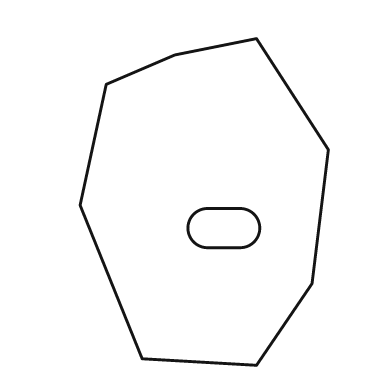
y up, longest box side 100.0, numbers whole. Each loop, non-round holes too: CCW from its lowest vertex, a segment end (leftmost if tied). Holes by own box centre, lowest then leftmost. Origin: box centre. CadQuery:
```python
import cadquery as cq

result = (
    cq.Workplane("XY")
    .moveTo(16.0, -50.0)
    .lineTo(33.0, -25.0)
    .lineTo(38.0, 16.0)
    .lineTo(16.0, 50.0)
    .lineTo(-9.0, 45.0)
    .lineTo(-30.0, 36.0)
    .lineTo(-38.0, -1.0)
    .lineTo(-19.0, -48.0)
    .close()
    .moveTo(1.0, -14.0)
    .lineTo(11.0, -14.0)
    .threePointArc((17.0, -8.0), (11.0, -2.0))
    .lineTo(1.0, -2.0)
    .threePointArc((-5.0, -8.0), (1.0, -14.0))
    .close()
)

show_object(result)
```